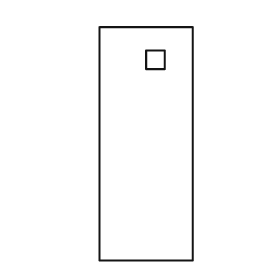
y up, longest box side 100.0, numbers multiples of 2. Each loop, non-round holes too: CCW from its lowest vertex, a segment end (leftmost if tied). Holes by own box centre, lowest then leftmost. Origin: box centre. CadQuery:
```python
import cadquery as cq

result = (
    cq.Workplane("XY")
    .moveTo(-20.0, -50.0)
    .lineTo(20.0, -50.0)
    .lineTo(20.0, 50.0)
    .lineTo(-20.0, 50.0)
    .close()
    .moveTo(0.0, 32.0)
    .lineTo(8.0, 32.0)
    .lineTo(8.0, 40.0)
    .lineTo(0.0, 40.0)
    .close()
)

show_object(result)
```